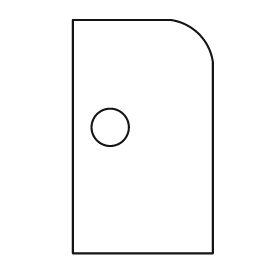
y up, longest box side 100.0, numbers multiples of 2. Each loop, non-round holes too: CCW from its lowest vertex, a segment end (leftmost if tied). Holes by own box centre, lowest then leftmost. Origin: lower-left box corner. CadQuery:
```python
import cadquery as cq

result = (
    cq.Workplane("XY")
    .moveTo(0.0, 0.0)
    .lineTo(60.0, 0.0)
    .lineTo(60.0, 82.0)
    .threePointArc((54.0, 94.0), (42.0, 100.0))
    .lineTo(0.0, 100.0)
    .close()
    .moveTo(16.0, 54.0)
    .circle(8.0)
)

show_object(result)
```